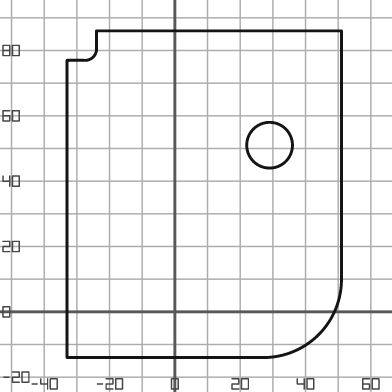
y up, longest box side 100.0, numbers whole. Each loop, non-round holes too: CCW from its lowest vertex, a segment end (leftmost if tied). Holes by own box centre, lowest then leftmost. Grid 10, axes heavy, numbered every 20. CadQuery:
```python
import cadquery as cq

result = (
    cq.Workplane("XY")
    .moveTo(-33.0, -14.0)
    .lineTo(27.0, -14.0)
    .threePointArc((44.0, -7.0), (51.0, 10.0))
    .lineTo(51.0, 86.0)
    .lineTo(-24.0, 86.0)
    .lineTo(-24.0, 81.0)
    .threePointArc((-25.0, 78.0), (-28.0, 77.0))
    .lineTo(-33.0, 77.0)
    .close()
    .moveTo(29.0, 51.0)
    .circle(7.0)
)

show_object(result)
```